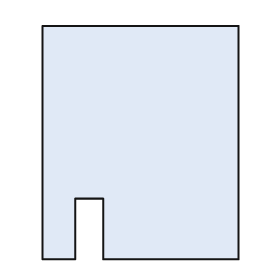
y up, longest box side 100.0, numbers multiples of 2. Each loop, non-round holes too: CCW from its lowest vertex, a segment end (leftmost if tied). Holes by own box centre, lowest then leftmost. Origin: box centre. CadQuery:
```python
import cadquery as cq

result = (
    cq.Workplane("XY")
    .moveTo(-42.0, -50.0)
    .lineTo(-28.0, -50.0)
    .lineTo(-28.0, -24.0)
    .lineTo(-16.0, -24.0)
    .lineTo(-16.0, -50.0)
    .lineTo(42.0, -50.0)
    .lineTo(42.0, 50.0)
    .lineTo(-42.0, 50.0)
    .close()
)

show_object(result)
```